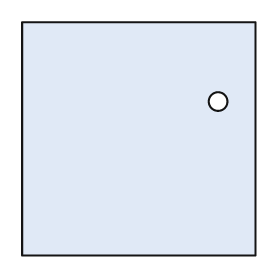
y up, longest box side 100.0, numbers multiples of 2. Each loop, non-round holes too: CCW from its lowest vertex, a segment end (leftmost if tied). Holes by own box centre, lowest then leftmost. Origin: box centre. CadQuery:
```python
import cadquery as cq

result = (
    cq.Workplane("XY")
    .moveTo(-50.0, -50.0)
    .lineTo(50.0, -50.0)
    .lineTo(50.0, 50.0)
    .lineTo(-50.0, 50.0)
    .close()
    .moveTo(34.0, 16.0)
    .circle(4.0)
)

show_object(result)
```